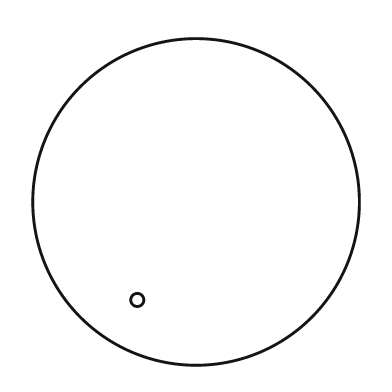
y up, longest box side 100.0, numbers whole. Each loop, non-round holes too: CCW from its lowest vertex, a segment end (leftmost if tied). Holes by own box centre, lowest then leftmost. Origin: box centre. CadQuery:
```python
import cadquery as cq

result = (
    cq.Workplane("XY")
    .moveTo(0.0, 0.0)
    .circle(50.0)
    .moveTo(-18.0, -30.0)
    .circle(2.0)
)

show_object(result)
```